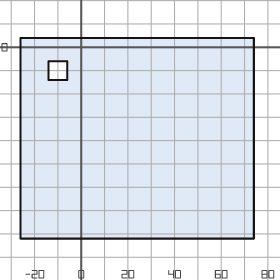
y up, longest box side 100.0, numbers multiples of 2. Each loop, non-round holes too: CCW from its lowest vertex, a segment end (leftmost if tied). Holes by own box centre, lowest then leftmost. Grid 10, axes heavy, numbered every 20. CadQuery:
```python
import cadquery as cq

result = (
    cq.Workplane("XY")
    .moveTo(-26.0, -82.0)
    .lineTo(74.0, -82.0)
    .lineTo(74.0, 4.0)
    .lineTo(-26.0, 4.0)
    .close()
    .moveTo(-14.0, -14.0)
    .lineTo(-6.0, -14.0)
    .lineTo(-6.0, -6.0)
    .lineTo(-14.0, -6.0)
    .close()
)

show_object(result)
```